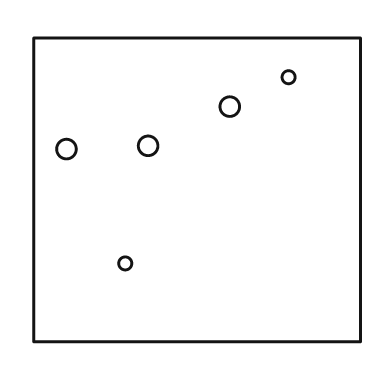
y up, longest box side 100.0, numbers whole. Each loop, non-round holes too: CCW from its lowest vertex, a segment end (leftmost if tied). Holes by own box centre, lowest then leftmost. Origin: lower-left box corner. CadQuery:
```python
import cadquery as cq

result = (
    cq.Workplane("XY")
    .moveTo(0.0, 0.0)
    .lineTo(100.0, 0.0)
    .lineTo(100.0, 93.0)
    .lineTo(0.0, 93.0)
    .close()
    .moveTo(28.0, 24.0)
    .circle(2.0)
    .moveTo(10.0, 59.0)
    .circle(3.0)
    .moveTo(35.0, 60.0)
    .circle(3.0)
    .moveTo(60.0, 72.0)
    .circle(3.0)
    .moveTo(78.0, 81.0)
    .circle(2.0)
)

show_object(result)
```